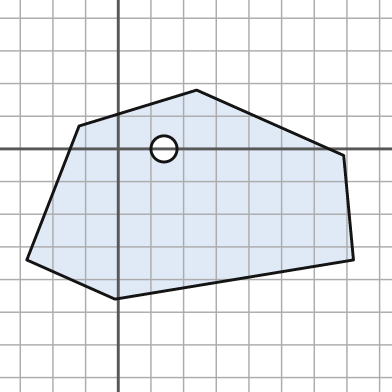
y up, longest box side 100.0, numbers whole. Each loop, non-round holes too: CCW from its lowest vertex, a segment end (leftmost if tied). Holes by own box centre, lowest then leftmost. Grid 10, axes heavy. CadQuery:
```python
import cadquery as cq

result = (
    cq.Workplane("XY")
    .moveTo(-1.0, -46.0)
    .lineTo(72.0, -34.0)
    .lineTo(69.0, -2.0)
    .lineTo(24.0, 18.0)
    .lineTo(-12.0, 7.0)
    .lineTo(-28.0, -34.0)
    .close()
    .moveTo(14.0, 0.0)
    .circle(4.0)
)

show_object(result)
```